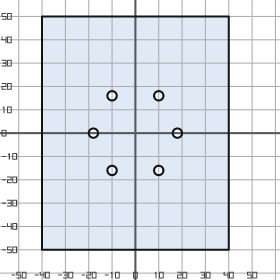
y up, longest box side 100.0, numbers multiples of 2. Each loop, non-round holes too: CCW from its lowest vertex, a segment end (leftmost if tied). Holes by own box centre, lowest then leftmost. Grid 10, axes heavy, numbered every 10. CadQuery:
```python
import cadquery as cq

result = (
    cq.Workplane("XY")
    .moveTo(-40.0, -50.0)
    .lineTo(40.0, -50.0)
    .lineTo(40.0, 50.0)
    .lineTo(-40.0, 50.0)
    .close()
    .moveTo(-10.0, -16.0)
    .circle(2.0)
    .moveTo(10.0, -16.0)
    .circle(2.0)
    .moveTo(-18.0, 0.0)
    .circle(2.0)
    .moveTo(18.0, 0.0)
    .circle(2.0)
    .moveTo(-10.0, 16.0)
    .circle(2.0)
    .moveTo(10.0, 16.0)
    .circle(2.0)
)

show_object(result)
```